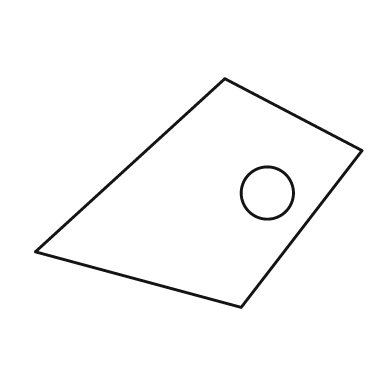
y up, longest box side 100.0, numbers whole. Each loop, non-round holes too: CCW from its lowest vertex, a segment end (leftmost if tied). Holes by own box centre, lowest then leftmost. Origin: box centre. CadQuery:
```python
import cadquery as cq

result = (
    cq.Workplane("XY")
    .moveTo(13.0, -35.0)
    .lineTo(50.0, 13.0)
    .lineTo(8.0, 35.0)
    .lineTo(-50.0, -18.0)
    .close()
    .moveTo(21.0, 0.0)
    .circle(8.0)
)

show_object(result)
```